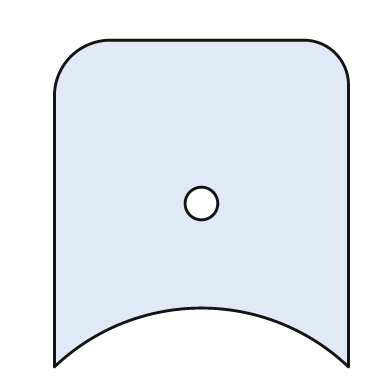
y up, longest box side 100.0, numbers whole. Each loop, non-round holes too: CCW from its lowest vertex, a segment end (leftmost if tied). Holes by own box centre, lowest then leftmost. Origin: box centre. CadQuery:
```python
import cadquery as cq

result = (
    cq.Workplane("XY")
    .moveTo(-45.0, -50.0)
    .threePointArc((0.0, -32.0), (45.0, -50.0))
    .lineTo(45.0, 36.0)
    .threePointArc((41.0, 46.0), (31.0, 50.0))
    .lineTo(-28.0, 50.0)
    .threePointArc((-40.0, 45.0), (-45.0, 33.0))
    .close()
    .moveTo(0.0, 0.0)
    .circle(5.0)
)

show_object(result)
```